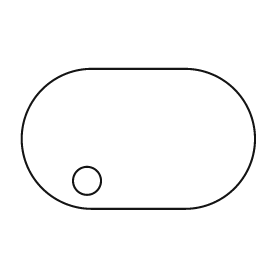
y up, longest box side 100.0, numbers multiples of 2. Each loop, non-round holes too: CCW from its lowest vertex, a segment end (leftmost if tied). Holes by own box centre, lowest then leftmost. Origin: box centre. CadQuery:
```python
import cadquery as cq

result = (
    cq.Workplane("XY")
    .moveTo(-20.0, -30.0)
    .lineTo(20.0, -30.0)
    .threePointArc((50.0, 0.0), (20.0, 30.0))
    .lineTo(-20.0, 30.0)
    .threePointArc((-50.0, 0.0), (-20.0, -30.0))
    .close()
    .moveTo(-22.0, -18.0)
    .circle(6.0)
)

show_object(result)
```